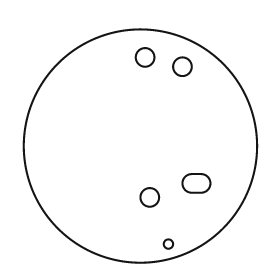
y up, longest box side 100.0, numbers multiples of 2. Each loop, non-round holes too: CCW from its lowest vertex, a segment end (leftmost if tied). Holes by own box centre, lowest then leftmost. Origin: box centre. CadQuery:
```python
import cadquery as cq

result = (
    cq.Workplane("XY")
    .moveTo(0.0, 0.0)
    .circle(50.0)
    .moveTo(12.0, -42.0)
    .circle(2.0)
    .moveTo(4.0, -22.0)
    .circle(4.0)
    .moveTo(22.0, -20.0)
    .lineTo(26.0, -20.0)
    .threePointArc((30.0, -16.0), (26.0, -12.0))
    .lineTo(22.0, -12.0)
    .threePointArc((18.0, -16.0), (22.0, -20.0))
    .close()
    .moveTo(18.0, 34.0)
    .circle(4.0)
    .moveTo(2.0, 38.0)
    .circle(4.0)
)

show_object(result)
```